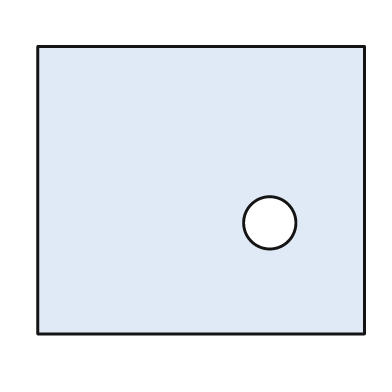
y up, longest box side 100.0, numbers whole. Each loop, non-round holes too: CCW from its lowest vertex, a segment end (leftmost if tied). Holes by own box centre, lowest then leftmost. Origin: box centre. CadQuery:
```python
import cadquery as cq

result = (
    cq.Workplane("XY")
    .moveTo(-50.0, -44.0)
    .lineTo(50.0, -44.0)
    .lineTo(50.0, 44.0)
    .lineTo(-50.0, 44.0)
    .close()
    .moveTo(21.0, -10.0)
    .circle(8.0)
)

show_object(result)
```